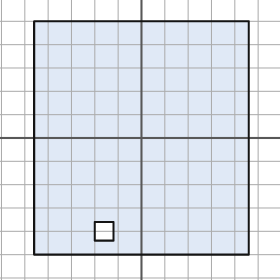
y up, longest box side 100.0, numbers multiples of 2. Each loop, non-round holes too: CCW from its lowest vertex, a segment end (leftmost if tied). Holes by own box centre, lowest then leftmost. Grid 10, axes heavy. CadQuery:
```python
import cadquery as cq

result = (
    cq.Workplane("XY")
    .moveTo(-46.0, -50.0)
    .lineTo(46.0, -50.0)
    .lineTo(46.0, 50.0)
    .lineTo(-46.0, 50.0)
    .close()
    .moveTo(-20.0, -44.0)
    .lineTo(-12.0, -44.0)
    .lineTo(-12.0, -36.0)
    .lineTo(-20.0, -36.0)
    .close()
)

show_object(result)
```